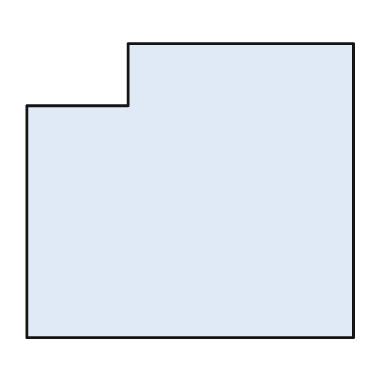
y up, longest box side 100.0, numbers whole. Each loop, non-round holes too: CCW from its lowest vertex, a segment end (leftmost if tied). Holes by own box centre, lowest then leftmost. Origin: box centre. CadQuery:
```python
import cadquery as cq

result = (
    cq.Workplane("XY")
    .moveTo(-50.0, -45.0)
    .lineTo(50.0, -45.0)
    .lineTo(50.0, 45.0)
    .lineTo(-19.0, 45.0)
    .lineTo(-19.0, 26.0)
    .lineTo(-50.0, 26.0)
    .close()
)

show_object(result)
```